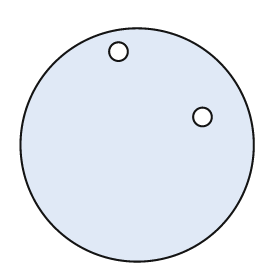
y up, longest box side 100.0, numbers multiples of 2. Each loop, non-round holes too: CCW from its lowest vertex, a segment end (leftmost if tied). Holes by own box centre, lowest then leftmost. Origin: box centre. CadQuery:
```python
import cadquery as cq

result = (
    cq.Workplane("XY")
    .moveTo(0.0, 0.0)
    .circle(50.0)
    .moveTo(28.0, 12.0)
    .circle(4.0)
    .moveTo(-8.0, 40.0)
    .circle(4.0)
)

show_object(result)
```